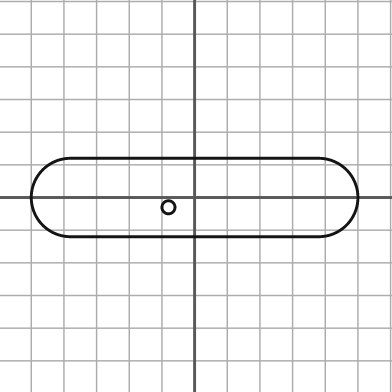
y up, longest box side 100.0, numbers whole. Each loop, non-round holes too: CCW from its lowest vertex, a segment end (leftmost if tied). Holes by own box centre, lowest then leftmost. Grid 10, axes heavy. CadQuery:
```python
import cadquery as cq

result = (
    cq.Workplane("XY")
    .moveTo(-38.0, -12.0)
    .lineTo(38.0, -12.0)
    .threePointArc((50.0, 0.0), (38.0, 12.0))
    .lineTo(-38.0, 12.0)
    .threePointArc((-50.0, 0.0), (-38.0, -12.0))
    .close()
    .moveTo(-8.0, -3.0)
    .circle(2.0)
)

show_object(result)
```